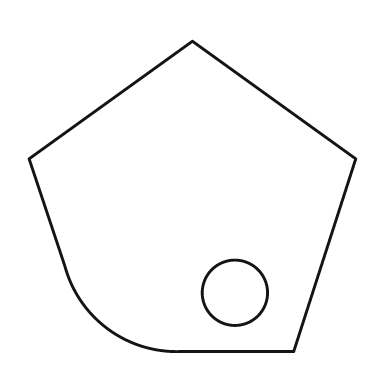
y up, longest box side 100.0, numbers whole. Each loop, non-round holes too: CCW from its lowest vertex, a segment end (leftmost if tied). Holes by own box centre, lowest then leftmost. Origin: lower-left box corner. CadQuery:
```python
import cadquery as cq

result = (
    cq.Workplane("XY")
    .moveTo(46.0, 0.0)
    .lineTo(81.0, 0.0)
    .lineTo(100.0, 59.0)
    .lineTo(50.0, 95.0)
    .lineTo(0.0, 59.0)
    .lineTo(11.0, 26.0)
    .threePointArc((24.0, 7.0), (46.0, 0.0))
    .close()
    .moveTo(63.0, 18.0)
    .circle(10.0)
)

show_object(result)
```